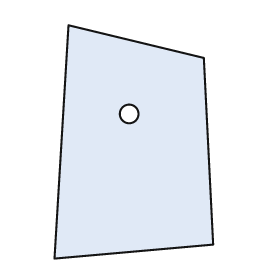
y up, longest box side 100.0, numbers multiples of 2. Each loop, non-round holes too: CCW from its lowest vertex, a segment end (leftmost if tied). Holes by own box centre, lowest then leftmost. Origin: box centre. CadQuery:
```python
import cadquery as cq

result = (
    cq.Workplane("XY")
    .moveTo(-34.0, -50.0)
    .lineTo(34.0, -44.0)
    .lineTo(30.0, 36.0)
    .lineTo(-28.0, 50.0)
    .close()
    .moveTo(-2.0, 12.0)
    .circle(4.0)
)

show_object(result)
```